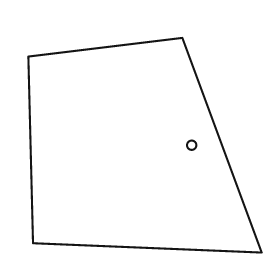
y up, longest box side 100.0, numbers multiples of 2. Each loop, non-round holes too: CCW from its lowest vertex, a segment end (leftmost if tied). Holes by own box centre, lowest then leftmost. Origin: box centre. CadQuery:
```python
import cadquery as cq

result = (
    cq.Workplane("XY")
    .moveTo(50.0, -46.0)
    .lineTo(16.0, 46.0)
    .lineTo(-50.0, 38.0)
    .lineTo(-48.0, -42.0)
    .close()
    .moveTo(20.0, 0.0)
    .circle(2.0)
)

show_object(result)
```